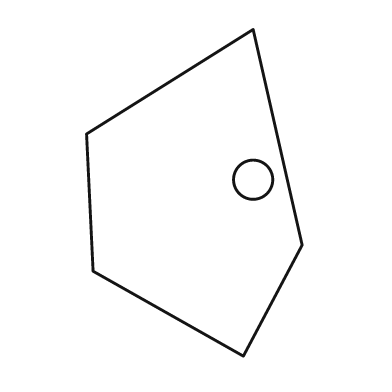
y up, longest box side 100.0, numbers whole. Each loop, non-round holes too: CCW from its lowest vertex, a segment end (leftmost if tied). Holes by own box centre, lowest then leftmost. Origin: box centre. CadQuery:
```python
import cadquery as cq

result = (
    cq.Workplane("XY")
    .moveTo(15.0, -50.0)
    .lineTo(33.0, -16.0)
    .lineTo(18.0, 50.0)
    .lineTo(-33.0, 18.0)
    .lineTo(-31.0, -24.0)
    .close()
    .moveTo(18.0, 4.0)
    .circle(6.0)
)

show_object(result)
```